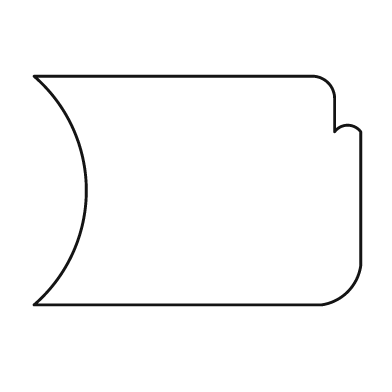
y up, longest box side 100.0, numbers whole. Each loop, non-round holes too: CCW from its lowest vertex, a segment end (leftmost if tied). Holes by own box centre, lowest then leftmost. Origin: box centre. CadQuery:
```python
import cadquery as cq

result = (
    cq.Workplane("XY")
    .moveTo(-50.0, -35.0)
    .lineTo(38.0, -35.0)
    .threePointArc((46.0, -31.0), (50.0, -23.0))
    .lineTo(50.0, 18.0)
    .threePointArc((46.0, 20.0), (42.0, 18.0))
    .lineTo(42.0, 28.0)
    .threePointArc((40.0, 33.0), (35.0, 35.0))
    .lineTo(-50.0, 35.0)
    .threePointArc((-34.0, 0.0), (-50.0, -35.0))
    .close()
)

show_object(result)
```